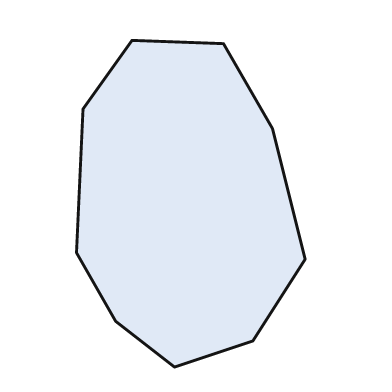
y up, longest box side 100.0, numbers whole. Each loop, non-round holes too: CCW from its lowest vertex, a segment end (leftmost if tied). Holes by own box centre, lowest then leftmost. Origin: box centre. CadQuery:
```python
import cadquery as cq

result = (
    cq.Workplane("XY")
    .moveTo(-5.0, -50.0)
    .lineTo(19.0, -42.0)
    .lineTo(35.0, -17.0)
    .lineTo(25.0, 23.0)
    .lineTo(10.0, 49.0)
    .lineTo(-18.0, 50.0)
    .lineTo(-33.0, 29.0)
    .lineTo(-35.0, -15.0)
    .lineTo(-23.0, -36.0)
    .close()
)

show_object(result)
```